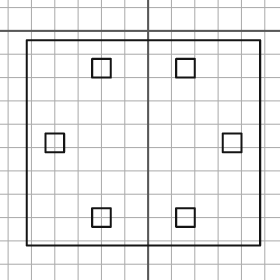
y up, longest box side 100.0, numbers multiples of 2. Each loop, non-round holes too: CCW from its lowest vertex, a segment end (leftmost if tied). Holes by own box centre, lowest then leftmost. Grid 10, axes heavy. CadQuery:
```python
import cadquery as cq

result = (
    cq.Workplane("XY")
    .moveTo(-52.0, -92.0)
    .lineTo(48.0, -92.0)
    .lineTo(48.0, -4.0)
    .lineTo(-52.0, -4.0)
    .close()
    .moveTo(-24.0, -84.0)
    .lineTo(-16.0, -84.0)
    .lineTo(-16.0, -76.0)
    .lineTo(-24.0, -76.0)
    .close()
    .moveTo(12.0, -84.0)
    .lineTo(20.0, -84.0)
    .lineTo(20.0, -76.0)
    .lineTo(12.0, -76.0)
    .close()
    .moveTo(-44.0, -52.0)
    .lineTo(-36.0, -52.0)
    .lineTo(-36.0, -44.0)
    .lineTo(-44.0, -44.0)
    .close()
    .moveTo(32.0, -52.0)
    .lineTo(40.0, -52.0)
    .lineTo(40.0, -44.0)
    .lineTo(32.0, -44.0)
    .close()
    .moveTo(-24.0, -20.0)
    .lineTo(-16.0, -20.0)
    .lineTo(-16.0, -12.0)
    .lineTo(-24.0, -12.0)
    .close()
    .moveTo(12.0, -20.0)
    .lineTo(20.0, -20.0)
    .lineTo(20.0, -12.0)
    .lineTo(12.0, -12.0)
    .close()
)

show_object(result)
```